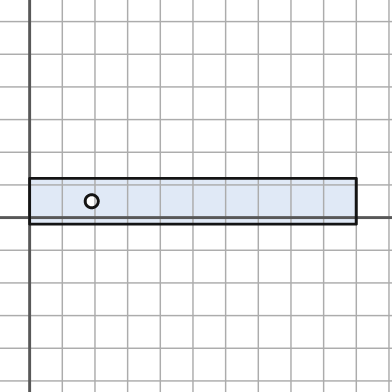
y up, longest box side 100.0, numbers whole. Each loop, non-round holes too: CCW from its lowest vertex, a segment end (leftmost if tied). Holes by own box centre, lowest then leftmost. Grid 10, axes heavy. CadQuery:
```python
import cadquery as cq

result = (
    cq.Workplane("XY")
    .moveTo(0.0, -2.0)
    .lineTo(100.0, -2.0)
    .lineTo(100.0, 12.0)
    .lineTo(0.0, 12.0)
    .close()
    .moveTo(19.0, 5.0)
    .circle(2.0)
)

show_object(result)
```